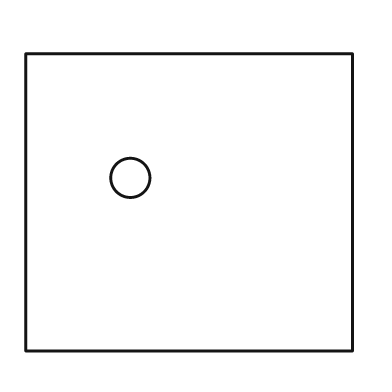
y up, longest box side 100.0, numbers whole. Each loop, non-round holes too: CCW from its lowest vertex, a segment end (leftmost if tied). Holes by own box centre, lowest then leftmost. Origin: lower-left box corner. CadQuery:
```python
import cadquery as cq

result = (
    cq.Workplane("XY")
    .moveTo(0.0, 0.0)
    .lineTo(100.0, 0.0)
    .lineTo(100.0, 91.0)
    .lineTo(0.0, 91.0)
    .close()
    .moveTo(32.0, 53.0)
    .circle(6.0)
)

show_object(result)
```